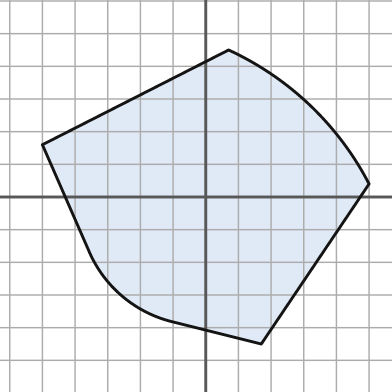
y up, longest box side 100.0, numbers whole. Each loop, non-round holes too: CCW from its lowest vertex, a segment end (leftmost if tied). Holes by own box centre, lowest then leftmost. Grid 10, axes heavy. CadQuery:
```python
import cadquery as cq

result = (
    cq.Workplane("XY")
    .moveTo(17.0, -45.0)
    .lineTo(50.0, 4.0)
    .threePointArc((32.0, 28.0), (7.0, 45.0))
    .lineTo(-50.0, 16.0)
    .lineTo(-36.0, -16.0)
    .threePointArc((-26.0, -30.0), (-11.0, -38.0))
    .close()
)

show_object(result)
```